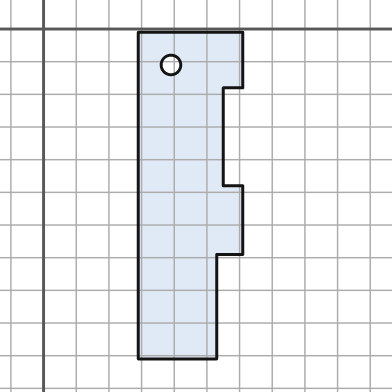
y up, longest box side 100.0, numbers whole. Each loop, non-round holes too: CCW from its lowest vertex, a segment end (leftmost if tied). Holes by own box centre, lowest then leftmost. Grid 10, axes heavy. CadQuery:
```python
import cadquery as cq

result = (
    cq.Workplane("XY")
    .moveTo(29.0, -101.0)
    .lineTo(53.0, -101.0)
    .lineTo(53.0, -69.0)
    .lineTo(61.0, -69.0)
    .lineTo(61.0, -48.0)
    .lineTo(55.0, -48.0)
    .lineTo(55.0, -18.0)
    .lineTo(61.0, -18.0)
    .lineTo(61.0, -1.0)
    .lineTo(29.0, -1.0)
    .close()
    .moveTo(39.0, -11.0)
    .circle(3.0)
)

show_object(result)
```